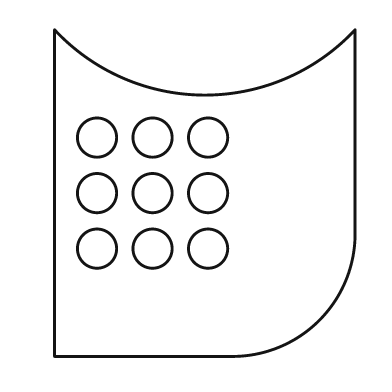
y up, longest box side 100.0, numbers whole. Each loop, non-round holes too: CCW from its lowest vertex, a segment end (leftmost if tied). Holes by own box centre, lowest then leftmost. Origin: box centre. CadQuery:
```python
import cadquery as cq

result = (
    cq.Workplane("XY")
    .moveTo(-46.0, -50.0)
    .lineTo(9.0, -50.0)
    .threePointArc((35.0, -39.0), (46.0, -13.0))
    .lineTo(46.0, 50.0)
    .threePointArc((0.0, 30.0), (-46.0, 50.0))
    .close()
    .moveTo(-33.0, -17.0)
    .circle(6.0)
    .moveTo(-16.0, -17.0)
    .circle(6.0)
    .moveTo(1.0, -17.0)
    .circle(6.0)
    .moveTo(-33.0, 0.0)
    .circle(6.0)
    .moveTo(-16.0, 0.0)
    .circle(6.0)
    .moveTo(1.0, 0.0)
    .circle(6.0)
    .moveTo(-33.0, 17.0)
    .circle(6.0)
    .moveTo(-16.0, 17.0)
    .circle(6.0)
    .moveTo(1.0, 17.0)
    .circle(6.0)
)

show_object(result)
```